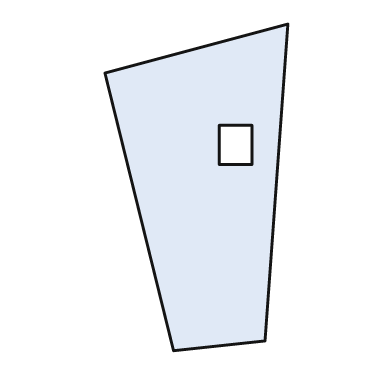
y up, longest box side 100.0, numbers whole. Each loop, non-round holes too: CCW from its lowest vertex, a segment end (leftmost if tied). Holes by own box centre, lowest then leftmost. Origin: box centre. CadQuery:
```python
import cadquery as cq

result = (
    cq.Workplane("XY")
    .moveTo(-7.0, -50.0)
    .lineTo(21.0, -47.0)
    .lineTo(28.0, 50.0)
    .lineTo(-28.0, 35.0)
    .close()
    .moveTo(7.0, 7.0)
    .lineTo(17.0, 7.0)
    .lineTo(17.0, 19.0)
    .lineTo(7.0, 19.0)
    .close()
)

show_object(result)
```